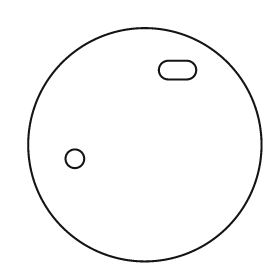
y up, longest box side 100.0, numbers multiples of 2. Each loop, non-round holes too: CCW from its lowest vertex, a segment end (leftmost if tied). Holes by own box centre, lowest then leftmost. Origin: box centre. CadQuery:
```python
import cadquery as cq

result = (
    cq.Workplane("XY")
    .moveTo(0.0, 0.0)
    .circle(50.0)
    .moveTo(-30.0, -6.0)
    .circle(4.0)
    .moveTo(10.0, 28.0)
    .lineTo(18.0, 28.0)
    .threePointArc((22.0, 32.0), (18.0, 36.0))
    .lineTo(10.0, 36.0)
    .threePointArc((6.0, 32.0), (10.0, 28.0))
    .close()
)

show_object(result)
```